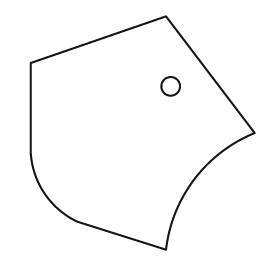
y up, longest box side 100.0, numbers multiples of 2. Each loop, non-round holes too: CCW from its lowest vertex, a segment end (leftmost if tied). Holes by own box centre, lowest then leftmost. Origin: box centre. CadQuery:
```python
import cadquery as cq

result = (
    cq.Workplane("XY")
    .moveTo(10.0, -50.0)
    .threePointArc((22.0, -20.0), (48.0, 0.0))
    .lineTo(10.0, 50.0)
    .lineTo(-48.0, 30.0)
    .lineTo(-48.0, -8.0)
    .threePointArc((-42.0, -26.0), (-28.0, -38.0))
    .close()
    .moveTo(12.0, 20.0)
    .circle(4.0)
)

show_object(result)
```